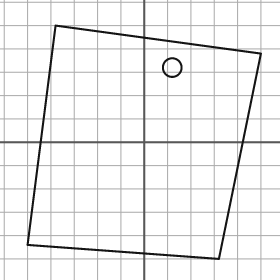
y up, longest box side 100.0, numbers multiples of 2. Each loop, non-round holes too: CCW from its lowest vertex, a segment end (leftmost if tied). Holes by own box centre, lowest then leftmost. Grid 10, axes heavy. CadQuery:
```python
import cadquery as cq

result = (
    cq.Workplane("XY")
    .moveTo(32.0, -50.0)
    .lineTo(50.0, 38.0)
    .lineTo(-38.0, 50.0)
    .lineTo(-50.0, -44.0)
    .close()
    .moveTo(12.0, 32.0)
    .circle(4.0)
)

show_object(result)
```